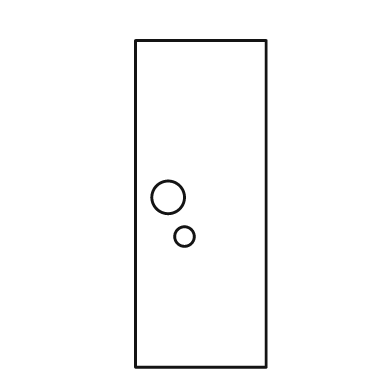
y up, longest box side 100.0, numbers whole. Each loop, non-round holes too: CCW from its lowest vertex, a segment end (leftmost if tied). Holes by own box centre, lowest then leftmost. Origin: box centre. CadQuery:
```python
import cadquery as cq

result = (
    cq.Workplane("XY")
    .moveTo(-20.0, -50.0)
    .lineTo(20.0, -50.0)
    .lineTo(20.0, 50.0)
    .lineTo(-20.0, 50.0)
    .close()
    .moveTo(-5.0, -10.0)
    .circle(3.0)
    .moveTo(-10.0, 2.0)
    .circle(5.0)
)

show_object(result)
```